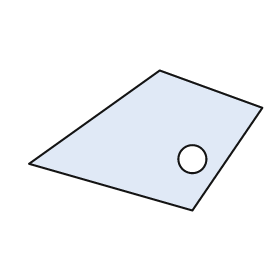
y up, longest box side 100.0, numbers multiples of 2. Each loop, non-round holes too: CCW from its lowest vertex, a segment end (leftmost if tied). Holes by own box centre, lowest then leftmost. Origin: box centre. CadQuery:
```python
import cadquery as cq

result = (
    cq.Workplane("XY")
    .moveTo(20.0, -30.0)
    .lineTo(50.0, 14.0)
    .lineTo(6.0, 30.0)
    .lineTo(-50.0, -10.0)
    .close()
    .moveTo(20.0, -8.0)
    .circle(6.0)
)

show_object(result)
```